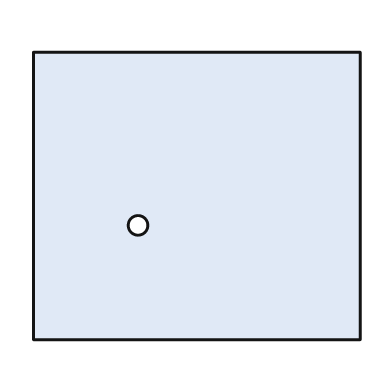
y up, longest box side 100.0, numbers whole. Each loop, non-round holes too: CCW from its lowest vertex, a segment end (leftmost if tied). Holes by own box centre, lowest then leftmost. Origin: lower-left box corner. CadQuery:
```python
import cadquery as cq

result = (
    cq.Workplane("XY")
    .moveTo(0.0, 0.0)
    .lineTo(100.0, 0.0)
    .lineTo(100.0, 88.0)
    .lineTo(0.0, 88.0)
    .close()
    .moveTo(32.0, 35.0)
    .circle(3.0)
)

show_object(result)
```